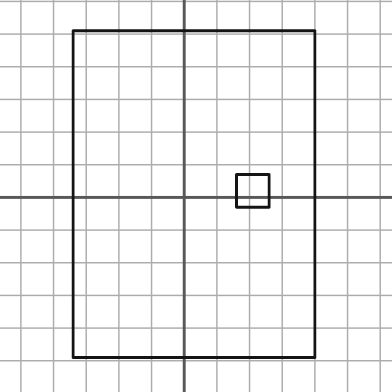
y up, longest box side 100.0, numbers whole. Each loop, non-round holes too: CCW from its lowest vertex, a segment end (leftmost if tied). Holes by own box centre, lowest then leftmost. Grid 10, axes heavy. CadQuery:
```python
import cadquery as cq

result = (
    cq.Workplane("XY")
    .moveTo(-34.0, -49.0)
    .lineTo(40.0, -49.0)
    .lineTo(40.0, 51.0)
    .lineTo(-34.0, 51.0)
    .close()
    .moveTo(16.0, -3.0)
    .lineTo(26.0, -3.0)
    .lineTo(26.0, 7.0)
    .lineTo(16.0, 7.0)
    .close()
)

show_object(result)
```